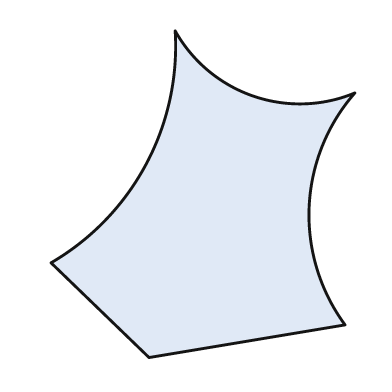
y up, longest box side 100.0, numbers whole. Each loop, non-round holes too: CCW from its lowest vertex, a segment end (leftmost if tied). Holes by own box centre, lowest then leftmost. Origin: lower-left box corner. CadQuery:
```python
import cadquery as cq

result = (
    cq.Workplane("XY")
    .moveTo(30.0, 0.0)
    .lineTo(90.0, 10.0)
    .threePointArc((79.0, 46.0), (93.0, 81.0))
    .threePointArc((62.0, 80.0), (38.0, 100.0))
    .threePointArc((29.0, 59.0), (0.0, 29.0))
    .close()
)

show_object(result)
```